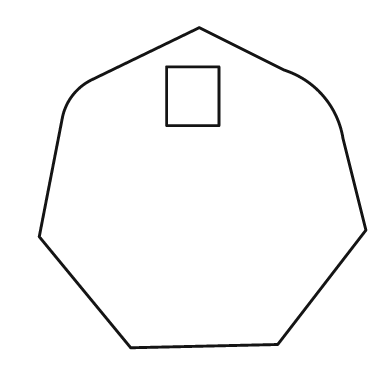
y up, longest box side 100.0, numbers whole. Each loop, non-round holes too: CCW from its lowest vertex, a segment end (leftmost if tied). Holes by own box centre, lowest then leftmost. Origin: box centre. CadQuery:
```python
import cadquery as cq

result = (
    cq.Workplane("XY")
    .moveTo(-22.0, -49.0)
    .lineTo(23.0, -48.0)
    .lineTo(50.0, -13.0)
    .lineTo(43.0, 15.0)
    .threePointArc((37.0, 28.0), (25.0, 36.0))
    .lineTo(-1.0, 49.0)
    .lineTo(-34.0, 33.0)
    .threePointArc((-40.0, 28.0), (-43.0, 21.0))
    .lineTo(-50.0, -15.0)
    .close()
    .moveTo(-11.0, 19.0)
    .lineTo(5.0, 19.0)
    .lineTo(5.0, 37.0)
    .lineTo(-11.0, 37.0)
    .close()
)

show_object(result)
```